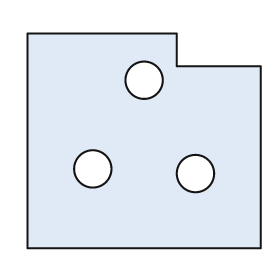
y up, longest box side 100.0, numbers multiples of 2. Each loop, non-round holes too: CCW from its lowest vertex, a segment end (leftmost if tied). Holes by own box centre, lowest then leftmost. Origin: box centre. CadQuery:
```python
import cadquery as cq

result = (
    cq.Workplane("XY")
    .moveTo(-50.0, -46.0)
    .lineTo(50.0, -46.0)
    .lineTo(50.0, 32.0)
    .lineTo(14.0, 32.0)
    .lineTo(14.0, 46.0)
    .lineTo(-50.0, 46.0)
    .close()
    .moveTo(22.0, -14.0)
    .circle(8.0)
    .moveTo(-22.0, -12.0)
    .circle(8.0)
    .moveTo(0.0, 26.0)
    .circle(8.0)
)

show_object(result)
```